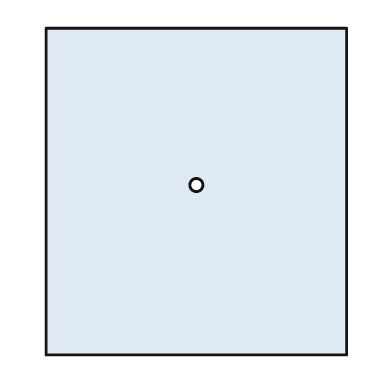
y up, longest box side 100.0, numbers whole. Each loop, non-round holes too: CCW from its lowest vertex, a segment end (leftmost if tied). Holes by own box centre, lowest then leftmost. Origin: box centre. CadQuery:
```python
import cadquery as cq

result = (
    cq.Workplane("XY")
    .moveTo(-46.0, -50.0)
    .lineTo(46.0, -50.0)
    .lineTo(46.0, 50.0)
    .lineTo(-46.0, 50.0)
    .close()
    .moveTo(0.0, 2.0)
    .circle(2.0)
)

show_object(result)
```